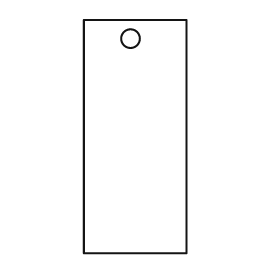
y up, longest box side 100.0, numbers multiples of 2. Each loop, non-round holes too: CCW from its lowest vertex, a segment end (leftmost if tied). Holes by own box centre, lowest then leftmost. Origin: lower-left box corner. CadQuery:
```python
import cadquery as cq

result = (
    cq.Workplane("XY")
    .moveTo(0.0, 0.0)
    .lineTo(44.0, 0.0)
    .lineTo(44.0, 100.0)
    .lineTo(0.0, 100.0)
    .close()
    .moveTo(20.0, 92.0)
    .circle(4.0)
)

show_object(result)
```